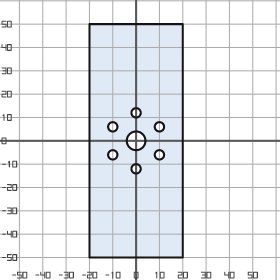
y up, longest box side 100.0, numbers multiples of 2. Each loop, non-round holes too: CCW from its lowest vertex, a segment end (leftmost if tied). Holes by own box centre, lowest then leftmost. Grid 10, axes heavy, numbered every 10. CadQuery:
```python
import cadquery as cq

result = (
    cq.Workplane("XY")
    .moveTo(-20.0, -50.0)
    .lineTo(20.0, -50.0)
    .lineTo(20.0, 50.0)
    .lineTo(-20.0, 50.0)
    .close()
    .moveTo(0.0, -12.0)
    .circle(2.0)
    .moveTo(-10.0, -6.0)
    .circle(2.0)
    .moveTo(10.0, -6.0)
    .circle(2.0)
    .moveTo(0.0, 0.0)
    .circle(4.0)
    .moveTo(-10.0, 6.0)
    .circle(2.0)
    .moveTo(10.0, 6.0)
    .circle(2.0)
    .moveTo(0.0, 12.0)
    .circle(2.0)
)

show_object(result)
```